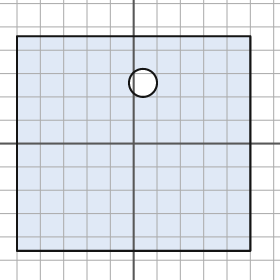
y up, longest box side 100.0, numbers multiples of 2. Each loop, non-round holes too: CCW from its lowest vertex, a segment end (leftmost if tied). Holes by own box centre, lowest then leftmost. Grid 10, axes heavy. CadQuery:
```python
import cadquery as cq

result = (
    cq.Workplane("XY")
    .moveTo(-50.0, -46.0)
    .lineTo(50.0, -46.0)
    .lineTo(50.0, 46.0)
    .lineTo(-50.0, 46.0)
    .close()
    .moveTo(4.0, 26.0)
    .circle(6.0)
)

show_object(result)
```